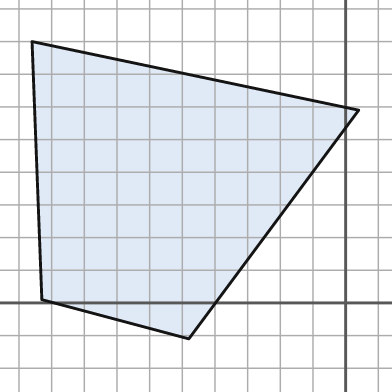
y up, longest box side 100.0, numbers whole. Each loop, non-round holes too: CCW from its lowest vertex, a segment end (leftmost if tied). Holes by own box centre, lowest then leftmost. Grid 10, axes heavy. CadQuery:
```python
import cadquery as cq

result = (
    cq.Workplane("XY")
    .moveTo(-48.0, -11.0)
    .lineTo(4.0, 59.0)
    .lineTo(-96.0, 80.0)
    .lineTo(-93.0, 1.0)
    .close()
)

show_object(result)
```